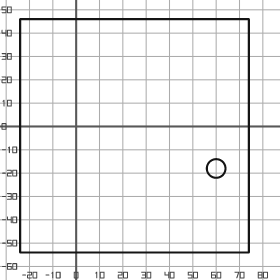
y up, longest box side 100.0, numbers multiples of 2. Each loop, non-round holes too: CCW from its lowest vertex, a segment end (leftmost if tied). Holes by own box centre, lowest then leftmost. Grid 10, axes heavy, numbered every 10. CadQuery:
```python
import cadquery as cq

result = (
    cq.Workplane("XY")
    .moveTo(-24.0, -54.0)
    .lineTo(74.0, -54.0)
    .lineTo(74.0, 46.0)
    .lineTo(-24.0, 46.0)
    .close()
    .moveTo(60.0, -18.0)
    .circle(4.0)
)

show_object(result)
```